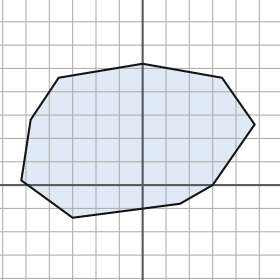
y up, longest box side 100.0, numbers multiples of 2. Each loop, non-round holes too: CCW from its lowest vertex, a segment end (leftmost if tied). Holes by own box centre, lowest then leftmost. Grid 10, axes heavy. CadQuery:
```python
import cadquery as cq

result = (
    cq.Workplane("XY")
    .moveTo(-30.0, -14.0)
    .lineTo(16.0, -8.0)
    .lineTo(30.0, 0.0)
    .lineTo(48.0, 26.0)
    .lineTo(34.0, 46.0)
    .lineTo(0.0, 52.0)
    .lineTo(-36.0, 46.0)
    .lineTo(-48.0, 28.0)
    .lineTo(-52.0, 2.0)
    .close()
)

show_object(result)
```